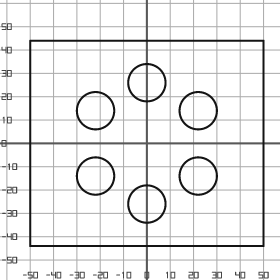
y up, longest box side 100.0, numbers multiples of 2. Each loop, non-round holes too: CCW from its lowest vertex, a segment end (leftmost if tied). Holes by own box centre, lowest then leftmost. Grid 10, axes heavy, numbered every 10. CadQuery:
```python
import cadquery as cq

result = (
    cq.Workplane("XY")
    .moveTo(-50.0, -44.0)
    .lineTo(50.0, -44.0)
    .lineTo(50.0, 44.0)
    .lineTo(-50.0, 44.0)
    .close()
    .moveTo(0.0, -26.0)
    .circle(8.0)
    .moveTo(-22.0, -14.0)
    .circle(8.0)
    .moveTo(22.0, -14.0)
    .circle(8.0)
    .moveTo(-22.0, 14.0)
    .circle(8.0)
    .moveTo(22.0, 14.0)
    .circle(8.0)
    .moveTo(0.0, 26.0)
    .circle(8.0)
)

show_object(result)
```